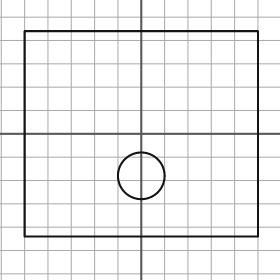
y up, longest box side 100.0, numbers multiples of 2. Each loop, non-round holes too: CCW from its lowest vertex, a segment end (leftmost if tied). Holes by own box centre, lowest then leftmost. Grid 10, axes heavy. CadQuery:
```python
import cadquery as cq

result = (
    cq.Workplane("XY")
    .moveTo(-50.0, -44.0)
    .lineTo(50.0, -44.0)
    .lineTo(50.0, 44.0)
    .lineTo(-50.0, 44.0)
    .close()
    .moveTo(0.0, -18.0)
    .circle(10.0)
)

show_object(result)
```